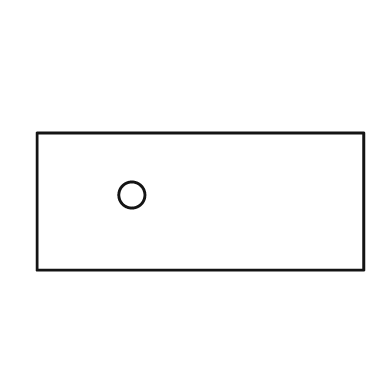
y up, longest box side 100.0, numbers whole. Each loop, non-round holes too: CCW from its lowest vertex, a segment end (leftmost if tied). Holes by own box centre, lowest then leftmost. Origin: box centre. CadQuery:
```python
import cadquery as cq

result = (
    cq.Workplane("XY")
    .moveTo(-50.0, -21.0)
    .lineTo(50.0, -21.0)
    .lineTo(50.0, 21.0)
    .lineTo(-50.0, 21.0)
    .close()
    .moveTo(-21.0, 2.0)
    .circle(4.0)
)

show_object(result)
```